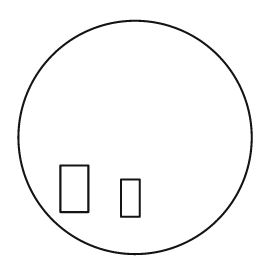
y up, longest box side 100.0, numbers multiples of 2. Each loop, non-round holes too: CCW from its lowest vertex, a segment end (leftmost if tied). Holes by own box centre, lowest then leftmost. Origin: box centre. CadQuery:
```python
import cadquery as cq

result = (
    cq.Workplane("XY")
    .moveTo(0.0, 0.0)
    .circle(50.0)
    .moveTo(-6.0, -34.0)
    .lineTo(2.0, -34.0)
    .lineTo(2.0, -18.0)
    .lineTo(-6.0, -18.0)
    .close()
    .moveTo(-32.0, -32.0)
    .lineTo(-20.0, -32.0)
    .lineTo(-20.0, -12.0)
    .lineTo(-32.0, -12.0)
    .close()
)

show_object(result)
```